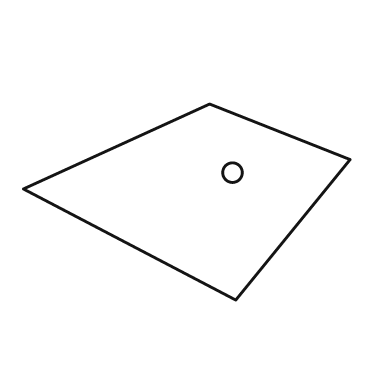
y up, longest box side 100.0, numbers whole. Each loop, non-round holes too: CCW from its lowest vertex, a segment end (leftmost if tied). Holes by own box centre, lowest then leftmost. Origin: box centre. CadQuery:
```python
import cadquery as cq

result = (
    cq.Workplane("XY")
    .moveTo(15.0, -30.0)
    .lineTo(50.0, 13.0)
    .lineTo(7.0, 30.0)
    .lineTo(-50.0, 4.0)
    .close()
    .moveTo(14.0, 9.0)
    .circle(3.0)
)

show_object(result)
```